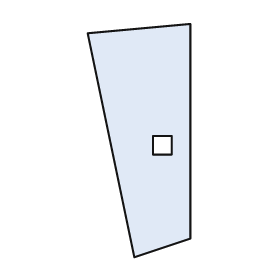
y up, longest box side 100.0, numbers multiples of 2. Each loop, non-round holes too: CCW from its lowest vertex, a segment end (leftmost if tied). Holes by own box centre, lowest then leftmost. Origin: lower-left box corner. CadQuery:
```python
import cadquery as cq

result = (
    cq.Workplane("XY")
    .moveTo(20.0, 0.0)
    .lineTo(44.0, 8.0)
    .lineTo(44.0, 100.0)
    .lineTo(0.0, 96.0)
    .close()
    .moveTo(28.0, 44.0)
    .lineTo(36.0, 44.0)
    .lineTo(36.0, 52.0)
    .lineTo(28.0, 52.0)
    .close()
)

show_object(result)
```